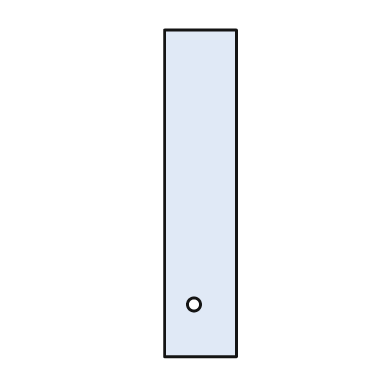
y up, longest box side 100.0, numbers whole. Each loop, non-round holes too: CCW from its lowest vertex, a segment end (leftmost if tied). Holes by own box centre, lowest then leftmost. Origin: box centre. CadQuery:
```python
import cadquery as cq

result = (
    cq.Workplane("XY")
    .moveTo(-11.0, -50.0)
    .lineTo(11.0, -50.0)
    .lineTo(11.0, 50.0)
    .lineTo(-11.0, 50.0)
    .close()
    .moveTo(-2.0, -34.0)
    .circle(2.0)
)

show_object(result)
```